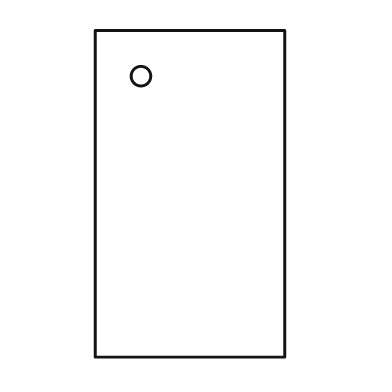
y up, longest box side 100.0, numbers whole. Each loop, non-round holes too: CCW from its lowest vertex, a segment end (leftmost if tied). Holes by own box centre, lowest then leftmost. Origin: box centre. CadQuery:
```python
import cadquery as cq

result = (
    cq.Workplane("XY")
    .moveTo(-29.0, -50.0)
    .lineTo(29.0, -50.0)
    .lineTo(29.0, 50.0)
    .lineTo(-29.0, 50.0)
    .close()
    .moveTo(-15.0, 36.0)
    .circle(3.0)
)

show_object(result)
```